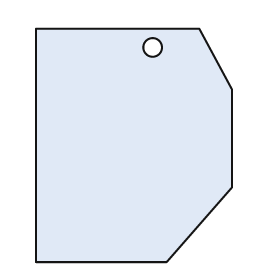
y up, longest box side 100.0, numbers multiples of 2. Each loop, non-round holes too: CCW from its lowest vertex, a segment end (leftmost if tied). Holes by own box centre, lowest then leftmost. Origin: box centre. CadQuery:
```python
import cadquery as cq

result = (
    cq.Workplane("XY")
    .moveTo(-42.0, -50.0)
    .lineTo(14.0, -50.0)
    .lineTo(42.0, -18.0)
    .lineTo(42.0, 24.0)
    .lineTo(28.0, 50.0)
    .lineTo(-42.0, 50.0)
    .close()
    .moveTo(8.0, 42.0)
    .circle(4.0)
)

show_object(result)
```